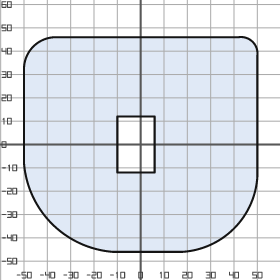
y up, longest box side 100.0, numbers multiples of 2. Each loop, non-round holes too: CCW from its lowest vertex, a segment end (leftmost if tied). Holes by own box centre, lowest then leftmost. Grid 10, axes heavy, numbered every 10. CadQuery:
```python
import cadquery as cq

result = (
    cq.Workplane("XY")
    .moveTo(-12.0, -46.0)
    .lineTo(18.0, -46.0)
    .threePointArc((40.0, -36.0), (50.0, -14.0))
    .lineTo(50.0, 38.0)
    .threePointArc((48.0, 44.0), (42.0, 46.0))
    .lineTo(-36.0, 46.0)
    .threePointArc((-46.0, 42.0), (-50.0, 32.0))
    .lineTo(-50.0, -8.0)
    .threePointArc((-38.0, -34.0), (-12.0, -46.0))
    .close()
    .moveTo(-10.0, -12.0)
    .lineTo(6.0, -12.0)
    .lineTo(6.0, 12.0)
    .lineTo(-10.0, 12.0)
    .close()
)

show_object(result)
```